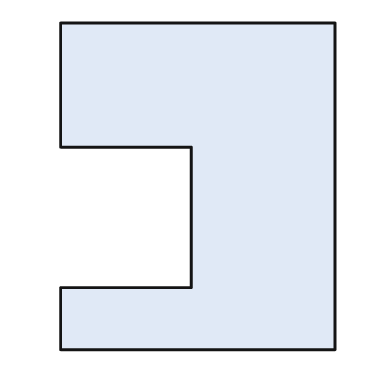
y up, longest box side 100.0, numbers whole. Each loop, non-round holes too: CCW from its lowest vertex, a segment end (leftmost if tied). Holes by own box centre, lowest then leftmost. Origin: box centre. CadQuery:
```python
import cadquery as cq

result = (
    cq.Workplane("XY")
    .moveTo(-42.0, -50.0)
    .lineTo(42.0, -50.0)
    .lineTo(42.0, 50.0)
    .lineTo(-42.0, 50.0)
    .lineTo(-42.0, 12.0)
    .lineTo(-2.0, 12.0)
    .lineTo(-2.0, -31.0)
    .lineTo(-42.0, -31.0)
    .close()
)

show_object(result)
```